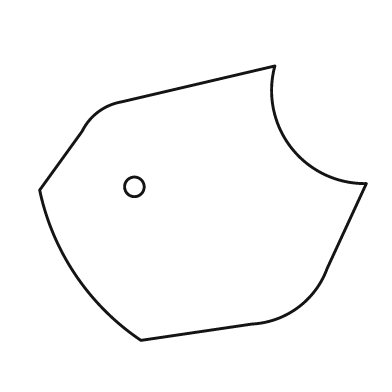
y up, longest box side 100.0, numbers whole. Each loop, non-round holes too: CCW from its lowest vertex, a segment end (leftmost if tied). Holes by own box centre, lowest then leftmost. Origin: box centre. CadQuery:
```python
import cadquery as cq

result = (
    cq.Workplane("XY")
    .moveTo(-19.0, -42.0)
    .lineTo(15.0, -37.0)
    .threePointArc((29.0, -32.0), (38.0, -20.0))
    .lineTo(50.0, 6.0)
    .threePointArc((27.0, 17.0), (22.0, 42.0))
    .lineTo(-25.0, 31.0)
    .threePointArc((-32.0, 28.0), (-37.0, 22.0))
    .lineTo(-50.0, 4.0)
    .threePointArc((-39.0, -22.0), (-19.0, -42.0))
    .close()
    .moveTo(-21.0, 5.0)
    .circle(3.0)
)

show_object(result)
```